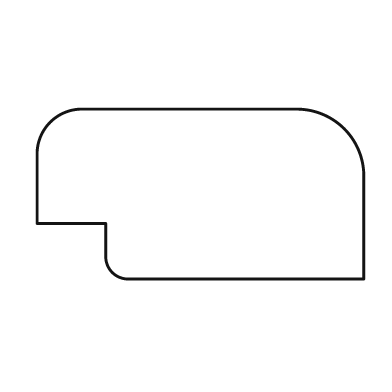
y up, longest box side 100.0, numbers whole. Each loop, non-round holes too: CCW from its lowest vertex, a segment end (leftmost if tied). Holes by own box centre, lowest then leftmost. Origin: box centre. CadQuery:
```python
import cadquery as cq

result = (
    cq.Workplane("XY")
    .moveTo(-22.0, -26.0)
    .lineTo(50.0, -26.0)
    .lineTo(50.0, 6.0)
    .threePointArc((44.0, 20.0), (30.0, 26.0))
    .lineTo(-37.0, 26.0)
    .threePointArc((-46.0, 22.0), (-50.0, 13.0))
    .lineTo(-50.0, -9.0)
    .lineTo(-29.0, -9.0)
    .lineTo(-29.0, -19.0)
    .threePointArc((-27.0, -24.0), (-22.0, -26.0))
    .close()
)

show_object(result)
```